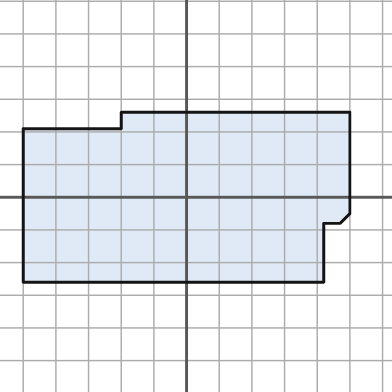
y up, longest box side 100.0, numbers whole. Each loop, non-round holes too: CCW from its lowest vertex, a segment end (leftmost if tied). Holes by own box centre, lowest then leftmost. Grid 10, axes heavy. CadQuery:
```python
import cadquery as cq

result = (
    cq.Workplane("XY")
    .moveTo(-50.0, -26.0)
    .lineTo(42.0, -26.0)
    .lineTo(42.0, -8.0)
    .lineTo(47.0, -8.0)
    .lineTo(50.0, -5.0)
    .lineTo(50.0, 26.0)
    .lineTo(-20.0, 26.0)
    .lineTo(-20.0, 21.0)
    .lineTo(-50.0, 21.0)
    .close()
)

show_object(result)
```